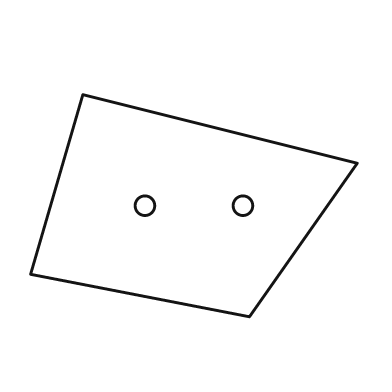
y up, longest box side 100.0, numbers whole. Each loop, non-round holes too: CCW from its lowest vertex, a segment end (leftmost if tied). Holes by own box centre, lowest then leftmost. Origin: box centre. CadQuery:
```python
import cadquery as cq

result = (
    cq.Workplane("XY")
    .moveTo(17.0, -34.0)
    .lineTo(50.0, 13.0)
    .lineTo(-34.0, 34.0)
    .lineTo(-50.0, -21.0)
    .close()
    .moveTo(-15.0, 0.0)
    .circle(3.0)
    .moveTo(15.0, 0.0)
    .circle(3.0)
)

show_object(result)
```